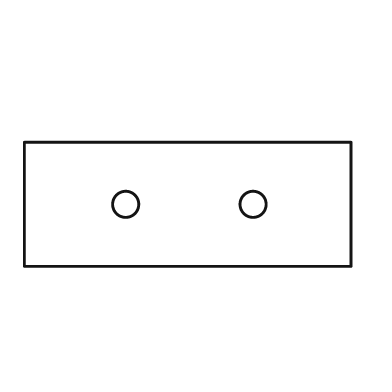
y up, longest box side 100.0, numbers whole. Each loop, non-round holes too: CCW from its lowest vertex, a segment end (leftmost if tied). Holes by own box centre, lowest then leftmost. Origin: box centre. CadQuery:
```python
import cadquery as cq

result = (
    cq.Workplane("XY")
    .moveTo(-50.0, -19.0)
    .lineTo(50.0, -19.0)
    .lineTo(50.0, 19.0)
    .lineTo(-50.0, 19.0)
    .close()
    .moveTo(-19.0, 0.0)
    .circle(4.0)
    .moveTo(20.0, 0.0)
    .circle(4.0)
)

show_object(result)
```